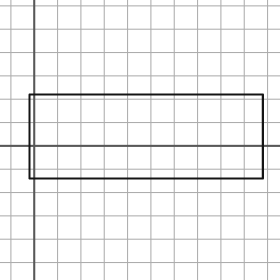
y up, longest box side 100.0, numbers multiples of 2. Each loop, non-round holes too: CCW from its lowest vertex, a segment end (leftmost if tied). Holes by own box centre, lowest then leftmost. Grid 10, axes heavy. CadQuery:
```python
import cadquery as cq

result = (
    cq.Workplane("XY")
    .moveTo(-2.0, -14.0)
    .lineTo(98.0, -14.0)
    .lineTo(98.0, 22.0)
    .lineTo(-2.0, 22.0)
    .close()
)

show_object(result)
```